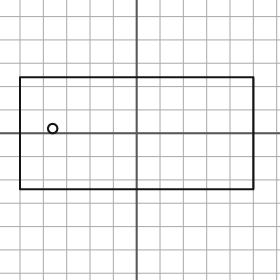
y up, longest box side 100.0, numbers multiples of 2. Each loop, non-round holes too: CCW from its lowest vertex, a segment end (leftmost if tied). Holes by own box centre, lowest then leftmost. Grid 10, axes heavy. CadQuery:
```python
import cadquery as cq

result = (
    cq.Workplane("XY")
    .moveTo(-50.0, -24.0)
    .lineTo(50.0, -24.0)
    .lineTo(50.0, 24.0)
    .lineTo(-50.0, 24.0)
    .close()
    .moveTo(-36.0, 2.0)
    .circle(2.0)
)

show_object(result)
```